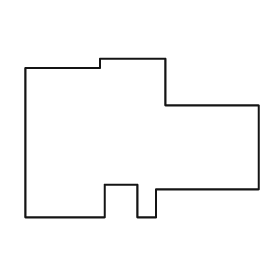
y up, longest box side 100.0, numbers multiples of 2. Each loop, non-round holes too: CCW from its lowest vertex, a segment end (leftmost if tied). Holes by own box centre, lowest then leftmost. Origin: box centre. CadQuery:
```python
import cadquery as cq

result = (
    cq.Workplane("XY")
    .moveTo(-50.0, -34.0)
    .lineTo(-16.0, -34.0)
    .lineTo(-16.0, -20.0)
    .lineTo(-2.0, -20.0)
    .lineTo(-2.0, -34.0)
    .lineTo(6.0, -34.0)
    .lineTo(6.0, -22.0)
    .lineTo(50.0, -22.0)
    .lineTo(50.0, 14.0)
    .lineTo(10.0, 14.0)
    .lineTo(10.0, 34.0)
    .lineTo(-18.0, 34.0)
    .lineTo(-18.0, 30.0)
    .lineTo(-50.0, 30.0)
    .close()
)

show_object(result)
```